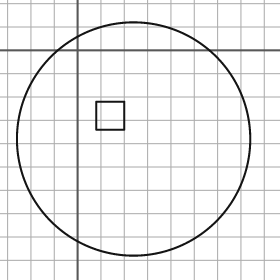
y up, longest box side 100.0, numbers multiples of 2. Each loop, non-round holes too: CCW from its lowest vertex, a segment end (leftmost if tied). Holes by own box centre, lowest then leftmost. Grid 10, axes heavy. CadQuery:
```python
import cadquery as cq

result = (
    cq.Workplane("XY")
    .moveTo(24.0, -38.0)
    .circle(50.0)
    .moveTo(8.0, -34.0)
    .lineTo(20.0, -34.0)
    .lineTo(20.0, -22.0)
    .lineTo(8.0, -22.0)
    .close()
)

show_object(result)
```